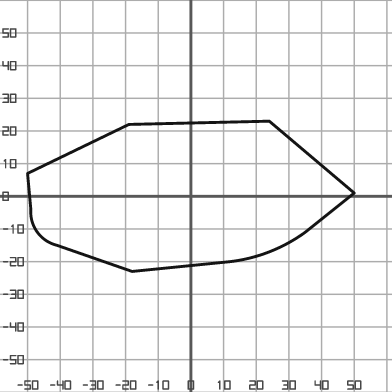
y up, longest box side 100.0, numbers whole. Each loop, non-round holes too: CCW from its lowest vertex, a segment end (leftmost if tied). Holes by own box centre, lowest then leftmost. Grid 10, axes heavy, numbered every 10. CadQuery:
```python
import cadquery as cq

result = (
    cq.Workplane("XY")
    .moveTo(-18.0, -23.0)
    .lineTo(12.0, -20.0)
    .threePointArc((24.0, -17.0), (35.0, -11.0))
    .lineTo(50.0, 1.0)
    .lineTo(24.0, 23.0)
    .lineTo(-19.0, 22.0)
    .lineTo(-50.0, 7.0)
    .lineTo(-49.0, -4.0)
    .threePointArc((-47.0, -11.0), (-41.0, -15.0))
    .close()
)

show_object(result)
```